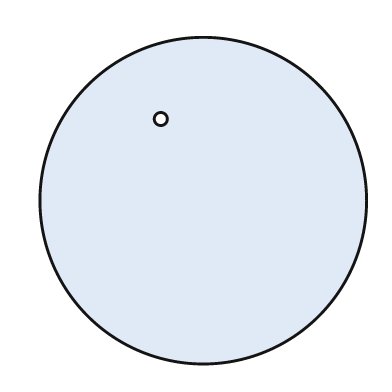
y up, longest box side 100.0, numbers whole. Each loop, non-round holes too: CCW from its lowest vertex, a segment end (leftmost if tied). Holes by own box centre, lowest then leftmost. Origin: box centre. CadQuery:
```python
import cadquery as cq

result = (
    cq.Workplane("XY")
    .moveTo(0.0, 0.0)
    .circle(50.0)
    .moveTo(-13.0, 25.0)
    .circle(2.0)
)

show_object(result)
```